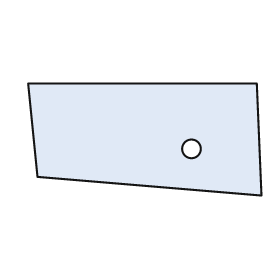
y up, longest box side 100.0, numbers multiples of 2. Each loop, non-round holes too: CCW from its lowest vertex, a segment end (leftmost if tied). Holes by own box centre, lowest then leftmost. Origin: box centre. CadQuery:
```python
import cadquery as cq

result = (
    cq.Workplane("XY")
    .moveTo(50.0, -24.0)
    .lineTo(48.0, 24.0)
    .lineTo(-50.0, 24.0)
    .lineTo(-46.0, -16.0)
    .close()
    .moveTo(20.0, -4.0)
    .circle(4.0)
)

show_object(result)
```